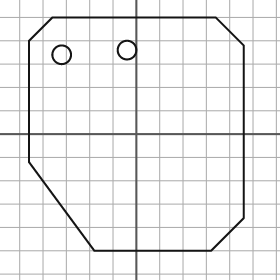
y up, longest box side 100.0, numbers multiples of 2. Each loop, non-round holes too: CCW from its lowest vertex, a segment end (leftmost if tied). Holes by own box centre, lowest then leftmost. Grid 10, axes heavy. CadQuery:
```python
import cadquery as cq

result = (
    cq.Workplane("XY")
    .moveTo(-18.0, -50.0)
    .lineTo(32.0, -50.0)
    .lineTo(46.0, -36.0)
    .lineTo(46.0, 38.0)
    .lineTo(34.0, 50.0)
    .lineTo(-36.0, 50.0)
    .lineTo(-46.0, 40.0)
    .lineTo(-46.0, -12.0)
    .close()
    .moveTo(-32.0, 34.0)
    .circle(4.0)
    .moveTo(-4.0, 36.0)
    .circle(4.0)
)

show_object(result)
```